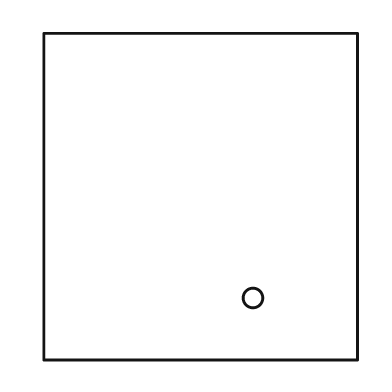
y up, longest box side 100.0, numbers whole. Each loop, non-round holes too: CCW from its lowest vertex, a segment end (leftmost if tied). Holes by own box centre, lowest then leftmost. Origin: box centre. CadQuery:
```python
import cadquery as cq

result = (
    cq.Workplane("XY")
    .moveTo(-48.0, -50.0)
    .lineTo(48.0, -50.0)
    .lineTo(48.0, 50.0)
    .lineTo(-48.0, 50.0)
    .close()
    .moveTo(16.0, -31.0)
    .circle(3.0)
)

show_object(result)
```